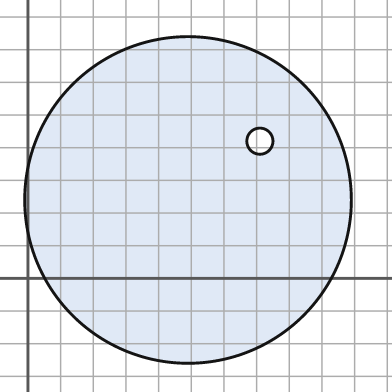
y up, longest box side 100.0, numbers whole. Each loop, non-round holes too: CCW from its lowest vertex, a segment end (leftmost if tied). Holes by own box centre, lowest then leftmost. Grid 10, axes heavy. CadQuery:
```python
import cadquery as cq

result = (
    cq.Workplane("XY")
    .moveTo(49.0, 24.0)
    .circle(50.0)
    .moveTo(71.0, 42.0)
    .circle(4.0)
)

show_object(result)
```